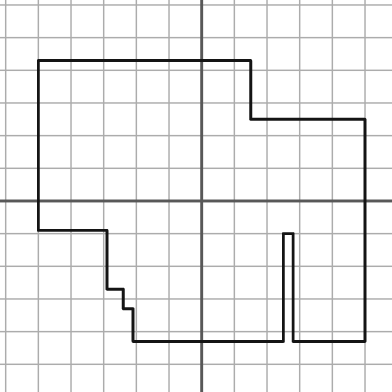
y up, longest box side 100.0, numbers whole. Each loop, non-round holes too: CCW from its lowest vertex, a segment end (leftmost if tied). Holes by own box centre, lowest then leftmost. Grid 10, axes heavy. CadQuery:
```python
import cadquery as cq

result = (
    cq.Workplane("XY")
    .moveTo(-21.0, -43.0)
    .lineTo(25.0, -43.0)
    .lineTo(25.0, -10.0)
    .lineTo(28.0, -10.0)
    .lineTo(28.0, -43.0)
    .lineTo(50.0, -43.0)
    .lineTo(50.0, 25.0)
    .lineTo(15.0, 25.0)
    .lineTo(15.0, 43.0)
    .lineTo(-50.0, 43.0)
    .lineTo(-50.0, -9.0)
    .lineTo(-29.0, -9.0)
    .lineTo(-29.0, -27.0)
    .lineTo(-24.0, -27.0)
    .lineTo(-24.0, -33.0)
    .lineTo(-21.0, -33.0)
    .close()
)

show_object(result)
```